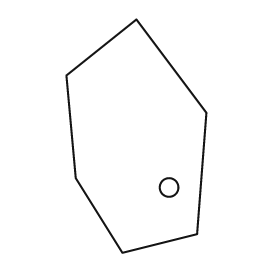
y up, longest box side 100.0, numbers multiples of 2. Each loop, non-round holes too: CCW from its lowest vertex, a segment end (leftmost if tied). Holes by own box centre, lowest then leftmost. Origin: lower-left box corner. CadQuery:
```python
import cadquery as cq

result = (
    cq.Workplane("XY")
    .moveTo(24.0, 0.0)
    .lineTo(56.0, 8.0)
    .lineTo(60.0, 60.0)
    .lineTo(30.0, 100.0)
    .lineTo(0.0, 76.0)
    .lineTo(4.0, 32.0)
    .close()
    .moveTo(44.0, 28.0)
    .circle(4.0)
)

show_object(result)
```